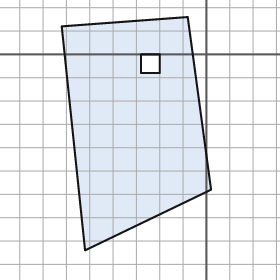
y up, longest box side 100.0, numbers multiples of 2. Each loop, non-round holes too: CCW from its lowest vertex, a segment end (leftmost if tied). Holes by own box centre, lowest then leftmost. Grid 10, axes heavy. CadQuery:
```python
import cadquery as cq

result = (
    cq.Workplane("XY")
    .moveTo(-52.0, -84.0)
    .lineTo(2.0, -58.0)
    .lineTo(-8.0, 16.0)
    .lineTo(-62.0, 12.0)
    .close()
    .moveTo(-28.0, -8.0)
    .lineTo(-20.0, -8.0)
    .lineTo(-20.0, 0.0)
    .lineTo(-28.0, 0.0)
    .close()
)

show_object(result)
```